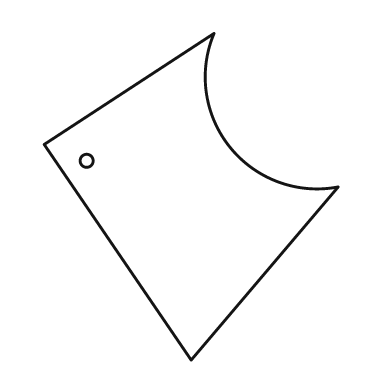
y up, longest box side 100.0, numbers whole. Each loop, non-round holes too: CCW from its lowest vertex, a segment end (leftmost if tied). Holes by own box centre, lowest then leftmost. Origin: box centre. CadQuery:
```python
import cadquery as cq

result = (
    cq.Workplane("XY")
    .moveTo(0.0, -50.0)
    .lineTo(45.0, 3.0)
    .threePointArc((12.0, 15.0), (7.0, 50.0))
    .lineTo(-45.0, 16.0)
    .close()
    .moveTo(-32.0, 11.0)
    .circle(2.0)
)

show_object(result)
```